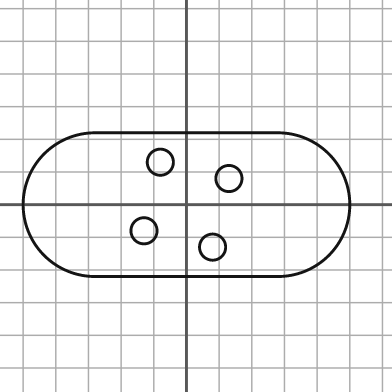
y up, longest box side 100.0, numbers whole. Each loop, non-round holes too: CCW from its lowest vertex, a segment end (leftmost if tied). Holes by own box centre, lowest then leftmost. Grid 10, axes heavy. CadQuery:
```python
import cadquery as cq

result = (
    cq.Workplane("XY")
    .moveTo(-28.0, -22.0)
    .lineTo(28.0, -22.0)
    .threePointArc((50.0, 0.0), (28.0, 22.0))
    .lineTo(-28.0, 22.0)
    .threePointArc((-50.0, 0.0), (-28.0, -22.0))
    .close()
    .moveTo(8.0, -13.0)
    .circle(4.0)
    .moveTo(-13.0, -8.0)
    .circle(4.0)
    .moveTo(13.0, 8.0)
    .circle(4.0)
    .moveTo(-8.0, 13.0)
    .circle(4.0)
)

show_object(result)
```